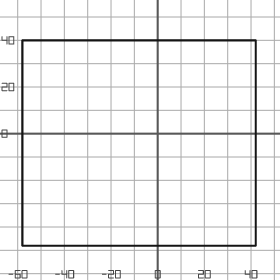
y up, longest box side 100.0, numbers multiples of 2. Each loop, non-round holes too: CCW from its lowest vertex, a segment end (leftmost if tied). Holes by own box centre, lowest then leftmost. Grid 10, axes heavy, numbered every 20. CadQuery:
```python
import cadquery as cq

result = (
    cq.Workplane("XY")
    .moveTo(-58.0, -48.0)
    .lineTo(42.0, -48.0)
    .lineTo(42.0, 40.0)
    .lineTo(-58.0, 40.0)
    .close()
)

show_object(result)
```